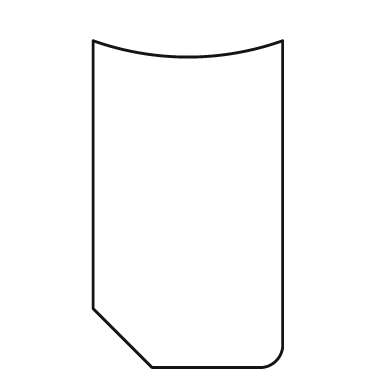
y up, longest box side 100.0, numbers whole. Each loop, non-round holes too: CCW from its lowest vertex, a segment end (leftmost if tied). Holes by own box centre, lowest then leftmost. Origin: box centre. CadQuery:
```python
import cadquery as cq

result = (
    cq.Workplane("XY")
    .moveTo(-11.0, -50.0)
    .lineTo(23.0, -50.0)
    .threePointArc((27.0, -48.0), (29.0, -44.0))
    .lineTo(29.0, 50.0)
    .threePointArc((0.0, 45.0), (-29.0, 50.0))
    .lineTo(-29.0, -32.0)
    .close()
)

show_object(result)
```